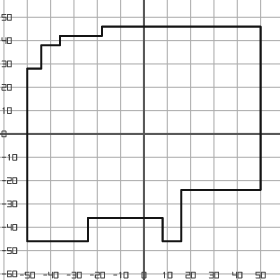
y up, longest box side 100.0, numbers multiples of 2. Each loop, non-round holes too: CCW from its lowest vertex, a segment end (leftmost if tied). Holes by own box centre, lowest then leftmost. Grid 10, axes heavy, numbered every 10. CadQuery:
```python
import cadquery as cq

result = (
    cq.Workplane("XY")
    .moveTo(-50.0, -46.0)
    .lineTo(-24.0, -46.0)
    .lineTo(-24.0, -36.0)
    .lineTo(8.0, -36.0)
    .lineTo(8.0, -46.0)
    .lineTo(16.0, -46.0)
    .lineTo(16.0, -24.0)
    .lineTo(50.0, -24.0)
    .lineTo(50.0, 46.0)
    .lineTo(-18.0, 46.0)
    .lineTo(-18.0, 42.0)
    .lineTo(-36.0, 42.0)
    .lineTo(-36.0, 38.0)
    .lineTo(-44.0, 38.0)
    .lineTo(-44.0, 28.0)
    .lineTo(-50.0, 28.0)
    .close()
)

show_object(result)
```